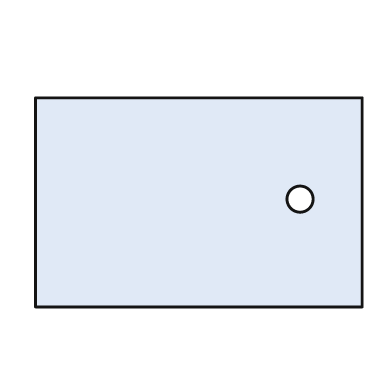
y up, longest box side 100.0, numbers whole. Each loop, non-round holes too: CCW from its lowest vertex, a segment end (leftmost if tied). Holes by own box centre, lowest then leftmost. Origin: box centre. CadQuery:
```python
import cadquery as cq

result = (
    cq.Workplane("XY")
    .moveTo(-50.0, -32.0)
    .lineTo(50.0, -32.0)
    .lineTo(50.0, 32.0)
    .lineTo(-50.0, 32.0)
    .close()
    .moveTo(31.0, 1.0)
    .circle(4.0)
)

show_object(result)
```